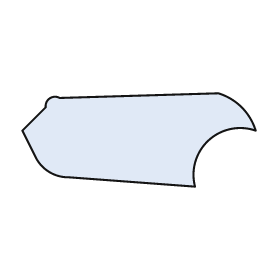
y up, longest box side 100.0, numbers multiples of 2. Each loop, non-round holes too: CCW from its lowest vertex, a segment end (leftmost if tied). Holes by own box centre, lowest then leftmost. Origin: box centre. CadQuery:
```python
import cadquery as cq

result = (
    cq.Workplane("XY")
    .moveTo(24.0, -20.0)
    .threePointArc((30.0, 0.0), (50.0, 4.0))
    .threePointArc((44.0, 14.0), (34.0, 20.0))
    .lineTo(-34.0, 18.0)
    .threePointArc((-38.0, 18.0), (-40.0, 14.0))
    .lineTo(-50.0, 4.0)
    .lineTo(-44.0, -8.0)
    .threePointArc((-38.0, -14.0), (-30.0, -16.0))
    .close()
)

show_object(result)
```